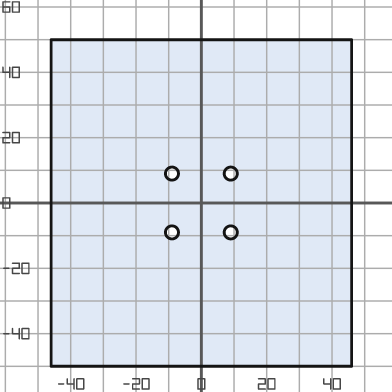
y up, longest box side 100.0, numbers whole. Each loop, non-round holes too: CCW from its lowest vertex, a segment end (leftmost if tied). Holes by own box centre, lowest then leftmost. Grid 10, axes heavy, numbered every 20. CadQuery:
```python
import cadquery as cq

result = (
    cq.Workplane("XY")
    .moveTo(-46.0, -50.0)
    .lineTo(46.0, -50.0)
    .lineTo(46.0, 50.0)
    .lineTo(-46.0, 50.0)
    .close()
    .moveTo(-9.0, -9.0)
    .circle(2.0)
    .moveTo(9.0, -9.0)
    .circle(2.0)
    .moveTo(-9.0, 9.0)
    .circle(2.0)
    .moveTo(9.0, 9.0)
    .circle(2.0)
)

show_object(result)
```